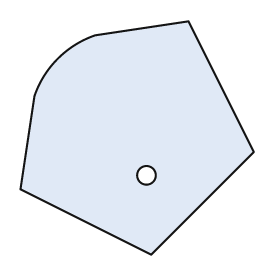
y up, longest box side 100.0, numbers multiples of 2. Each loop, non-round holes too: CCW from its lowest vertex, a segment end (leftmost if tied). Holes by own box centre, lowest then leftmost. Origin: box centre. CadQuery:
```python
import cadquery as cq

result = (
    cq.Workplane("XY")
    .moveTo(6.0, -50.0)
    .lineTo(50.0, -6.0)
    .lineTo(22.0, 50.0)
    .lineTo(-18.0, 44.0)
    .threePointArc((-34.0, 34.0), (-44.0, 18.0))
    .lineTo(-50.0, -22.0)
    .close()
    .moveTo(4.0, -16.0)
    .circle(4.0)
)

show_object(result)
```